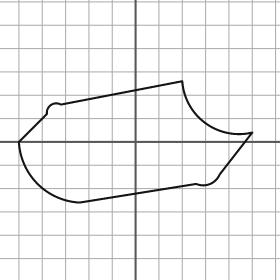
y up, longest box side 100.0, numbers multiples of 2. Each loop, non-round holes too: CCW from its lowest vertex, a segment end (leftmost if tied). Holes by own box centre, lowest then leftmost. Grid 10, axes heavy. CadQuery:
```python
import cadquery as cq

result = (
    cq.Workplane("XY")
    .moveTo(-24.0, -26.0)
    .lineTo(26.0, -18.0)
    .threePointArc((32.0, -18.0), (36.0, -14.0))
    .lineTo(50.0, 4.0)
    .threePointArc((30.0, 8.0), (20.0, 26.0))
    .lineTo(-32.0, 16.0)
    .threePointArc((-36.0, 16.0), (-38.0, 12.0))
    .lineTo(-50.0, 0.0)
    .threePointArc((-42.0, -18.0), (-24.0, -26.0))
    .close()
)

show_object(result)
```